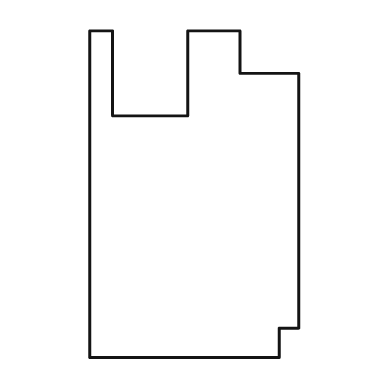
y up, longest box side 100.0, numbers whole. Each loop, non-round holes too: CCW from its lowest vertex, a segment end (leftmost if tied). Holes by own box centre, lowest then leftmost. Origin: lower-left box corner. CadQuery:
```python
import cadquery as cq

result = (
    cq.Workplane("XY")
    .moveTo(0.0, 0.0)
    .lineTo(58.0, 0.0)
    .lineTo(58.0, 9.0)
    .lineTo(64.0, 9.0)
    .lineTo(64.0, 87.0)
    .lineTo(46.0, 87.0)
    .lineTo(46.0, 100.0)
    .lineTo(30.0, 100.0)
    .lineTo(30.0, 74.0)
    .lineTo(7.0, 74.0)
    .lineTo(7.0, 100.0)
    .lineTo(0.0, 100.0)
    .close()
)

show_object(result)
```